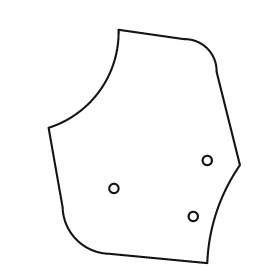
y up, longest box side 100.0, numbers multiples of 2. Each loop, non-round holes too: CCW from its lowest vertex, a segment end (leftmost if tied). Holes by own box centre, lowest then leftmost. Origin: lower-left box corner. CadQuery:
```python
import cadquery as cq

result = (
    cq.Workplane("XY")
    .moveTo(68.0, 0.0)
    .threePointArc((72.0, 22.0), (82.0, 42.0))
    .lineTo(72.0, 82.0)
    .threePointArc((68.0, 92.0), (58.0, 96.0))
    .lineTo(30.0, 100.0)
    .threePointArc((22.0, 74.0), (0.0, 58.0))
    .lineTo(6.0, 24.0)
    .threePointArc((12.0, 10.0), (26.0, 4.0))
    .close()
    .moveTo(62.0, 20.0)
    .circle(2.0)
    .moveTo(28.0, 32.0)
    .circle(2.0)
    .moveTo(68.0, 44.0)
    .circle(2.0)
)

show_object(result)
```